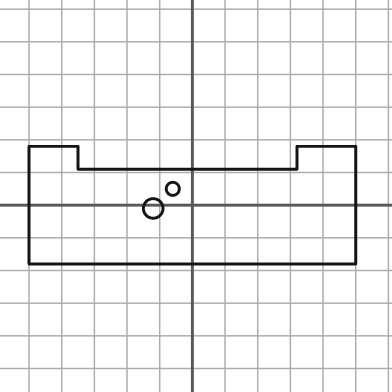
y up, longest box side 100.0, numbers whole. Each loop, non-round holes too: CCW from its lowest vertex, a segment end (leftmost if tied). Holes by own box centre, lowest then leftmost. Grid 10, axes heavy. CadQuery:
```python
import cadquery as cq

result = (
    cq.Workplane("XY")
    .moveTo(-50.0, -18.0)
    .lineTo(50.0, -18.0)
    .lineTo(50.0, 18.0)
    .lineTo(32.0, 18.0)
    .lineTo(32.0, 11.0)
    .lineTo(-35.0, 11.0)
    .lineTo(-35.0, 18.0)
    .lineTo(-50.0, 18.0)
    .close()
    .moveTo(-12.0, -1.0)
    .circle(3.0)
    .moveTo(-6.0, 5.0)
    .circle(2.0)
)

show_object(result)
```